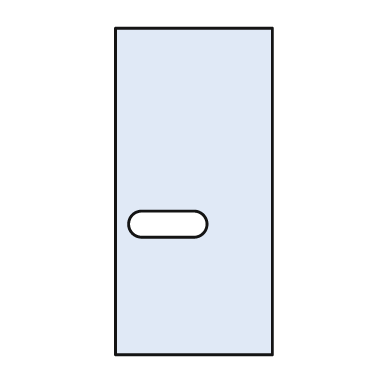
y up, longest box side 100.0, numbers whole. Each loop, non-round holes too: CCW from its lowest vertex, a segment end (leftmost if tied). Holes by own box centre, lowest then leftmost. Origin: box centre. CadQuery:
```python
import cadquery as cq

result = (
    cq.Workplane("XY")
    .moveTo(-24.0, -50.0)
    .lineTo(24.0, -50.0)
    .lineTo(24.0, 50.0)
    .lineTo(-24.0, 50.0)
    .close()
    .moveTo(-16.0, -14.0)
    .lineTo(0.0, -14.0)
    .threePointArc((4.0, -10.0), (0.0, -6.0))
    .lineTo(-16.0, -6.0)
    .threePointArc((-20.0, -10.0), (-16.0, -14.0))
    .close()
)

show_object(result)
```